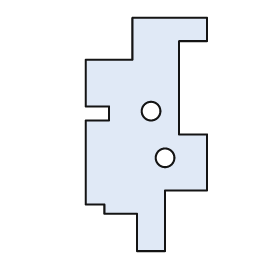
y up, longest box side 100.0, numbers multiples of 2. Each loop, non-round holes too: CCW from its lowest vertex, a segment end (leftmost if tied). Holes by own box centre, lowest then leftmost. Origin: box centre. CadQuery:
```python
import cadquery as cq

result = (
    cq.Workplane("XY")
    .moveTo(-4.0, -50.0)
    .lineTo(8.0, -50.0)
    .lineTo(8.0, -24.0)
    .lineTo(26.0, -24.0)
    .lineTo(26.0, 0.0)
    .lineTo(14.0, 0.0)
    .lineTo(14.0, 40.0)
    .lineTo(26.0, 40.0)
    .lineTo(26.0, 50.0)
    .lineTo(-6.0, 50.0)
    .lineTo(-6.0, 32.0)
    .lineTo(-26.0, 32.0)
    .lineTo(-26.0, 12.0)
    .lineTo(-16.0, 12.0)
    .lineTo(-16.0, 6.0)
    .lineTo(-26.0, 6.0)
    .lineTo(-26.0, -30.0)
    .lineTo(-18.0, -30.0)
    .lineTo(-18.0, -34.0)
    .lineTo(-4.0, -34.0)
    .close()
    .moveTo(8.0, -10.0)
    .circle(4.0)
    .moveTo(2.0, 10.0)
    .circle(4.0)
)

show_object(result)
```